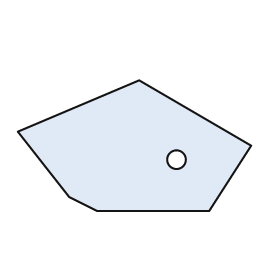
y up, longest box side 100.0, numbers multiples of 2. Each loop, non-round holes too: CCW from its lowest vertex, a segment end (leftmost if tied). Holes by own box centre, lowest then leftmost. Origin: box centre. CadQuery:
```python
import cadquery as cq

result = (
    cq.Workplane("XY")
    .moveTo(-16.0, -28.0)
    .lineTo(32.0, -28.0)
    .lineTo(50.0, 0.0)
    .lineTo(2.0, 28.0)
    .lineTo(-50.0, 6.0)
    .lineTo(-28.0, -22.0)
    .close()
    .moveTo(18.0, -6.0)
    .circle(4.0)
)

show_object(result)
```